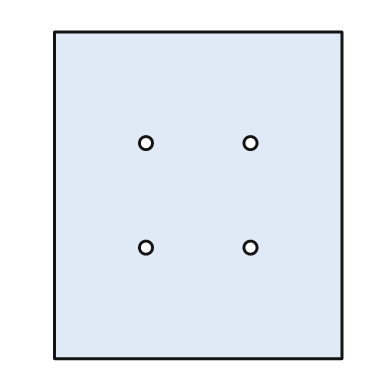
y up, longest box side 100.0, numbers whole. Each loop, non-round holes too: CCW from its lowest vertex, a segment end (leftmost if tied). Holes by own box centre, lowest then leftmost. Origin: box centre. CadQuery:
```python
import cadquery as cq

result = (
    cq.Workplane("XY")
    .moveTo(-44.0, -50.0)
    .lineTo(44.0, -50.0)
    .lineTo(44.0, 50.0)
    .lineTo(-44.0, 50.0)
    .close()
    .moveTo(-16.0, -16.0)
    .circle(2.0)
    .moveTo(16.0, -16.0)
    .circle(2.0)
    .moveTo(-16.0, 16.0)
    .circle(2.0)
    .moveTo(16.0, 16.0)
    .circle(2.0)
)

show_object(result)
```